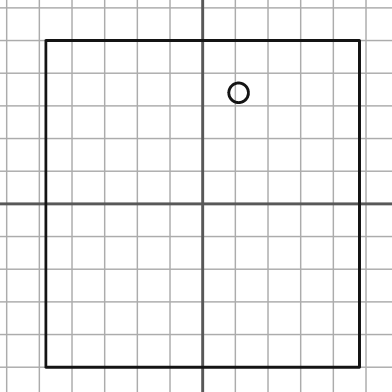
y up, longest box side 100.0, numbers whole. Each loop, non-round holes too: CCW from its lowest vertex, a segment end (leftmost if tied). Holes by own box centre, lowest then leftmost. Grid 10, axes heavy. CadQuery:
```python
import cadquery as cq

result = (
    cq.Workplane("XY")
    .moveTo(-48.0, -50.0)
    .lineTo(48.0, -50.0)
    .lineTo(48.0, 50.0)
    .lineTo(-48.0, 50.0)
    .close()
    .moveTo(11.0, 34.0)
    .circle(3.0)
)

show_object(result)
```